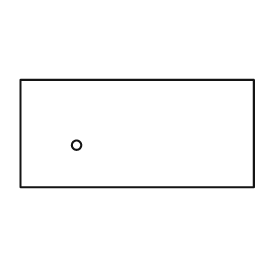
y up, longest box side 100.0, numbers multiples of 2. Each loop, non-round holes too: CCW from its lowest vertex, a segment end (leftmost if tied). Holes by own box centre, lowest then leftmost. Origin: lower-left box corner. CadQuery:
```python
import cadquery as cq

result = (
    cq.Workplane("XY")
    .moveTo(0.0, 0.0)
    .lineTo(100.0, 0.0)
    .lineTo(100.0, 46.0)
    .lineTo(0.0, 46.0)
    .close()
    .moveTo(24.0, 18.0)
    .circle(2.0)
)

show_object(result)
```